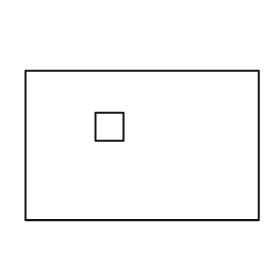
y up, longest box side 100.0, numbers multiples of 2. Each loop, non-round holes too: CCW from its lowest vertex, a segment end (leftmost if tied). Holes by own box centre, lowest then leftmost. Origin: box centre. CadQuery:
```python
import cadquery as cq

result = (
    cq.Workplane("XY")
    .moveTo(-50.0, -32.0)
    .lineTo(50.0, -32.0)
    .lineTo(50.0, 32.0)
    .lineTo(-50.0, 32.0)
    .close()
    .moveTo(-20.0, 2.0)
    .lineTo(-8.0, 2.0)
    .lineTo(-8.0, 14.0)
    .lineTo(-20.0, 14.0)
    .close()
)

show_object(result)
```